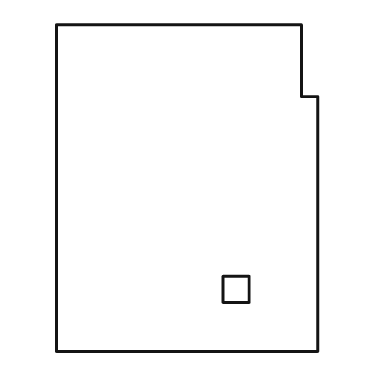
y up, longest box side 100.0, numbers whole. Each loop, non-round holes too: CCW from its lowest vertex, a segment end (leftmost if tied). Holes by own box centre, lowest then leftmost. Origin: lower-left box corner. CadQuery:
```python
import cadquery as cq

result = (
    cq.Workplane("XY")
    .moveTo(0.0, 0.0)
    .lineTo(80.0, 0.0)
    .lineTo(80.0, 78.0)
    .lineTo(75.0, 78.0)
    .lineTo(75.0, 100.0)
    .lineTo(0.0, 100.0)
    .close()
    .moveTo(51.0, 15.0)
    .lineTo(59.0, 15.0)
    .lineTo(59.0, 23.0)
    .lineTo(51.0, 23.0)
    .close()
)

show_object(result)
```